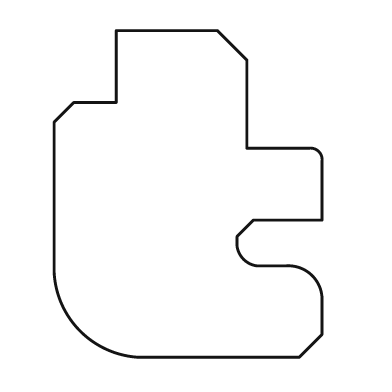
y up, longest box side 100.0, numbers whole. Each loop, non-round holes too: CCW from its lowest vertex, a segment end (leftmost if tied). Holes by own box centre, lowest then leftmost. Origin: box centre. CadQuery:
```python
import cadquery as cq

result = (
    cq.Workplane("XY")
    .moveTo(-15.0, -50.0)
    .lineTo(34.0, -50.0)
    .lineTo(41.0, -43.0)
    .lineTo(41.0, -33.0)
    .threePointArc((38.0, -25.0), (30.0, -22.0))
    .lineTo(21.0, -22.0)
    .threePointArc((17.0, -20.0), (15.0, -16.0))
    .lineTo(15.0, -13.0)
    .lineTo(20.0, -8.0)
    .lineTo(41.0, -8.0)
    .lineTo(41.0, 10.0)
    .threePointArc((40.0, 13.0), (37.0, 14.0))
    .lineTo(18.0, 14.0)
    .lineTo(18.0, 41.0)
    .lineTo(9.0, 50.0)
    .lineTo(-22.0, 50.0)
    .lineTo(-22.0, 28.0)
    .lineTo(-35.0, 28.0)
    .lineTo(-41.0, 22.0)
    .lineTo(-41.0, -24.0)
    .threePointArc((-33.0, -42.0), (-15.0, -50.0))
    .close()
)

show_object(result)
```